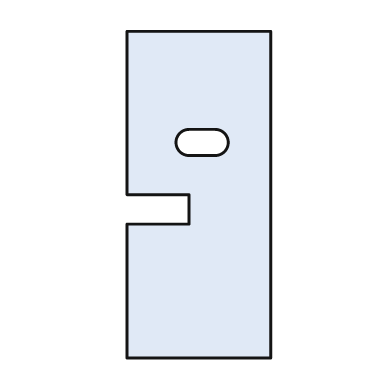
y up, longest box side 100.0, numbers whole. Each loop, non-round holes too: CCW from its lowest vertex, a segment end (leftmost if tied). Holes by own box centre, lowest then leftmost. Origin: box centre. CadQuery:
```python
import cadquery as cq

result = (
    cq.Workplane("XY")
    .moveTo(-22.0, -50.0)
    .lineTo(22.0, -50.0)
    .lineTo(22.0, 50.0)
    .lineTo(-22.0, 50.0)
    .lineTo(-22.0, 0.0)
    .lineTo(-3.0, 0.0)
    .lineTo(-3.0, -9.0)
    .lineTo(-22.0, -9.0)
    .close()
    .moveTo(-3.0, 12.0)
    .lineTo(5.0, 12.0)
    .threePointArc((9.0, 16.0), (5.0, 20.0))
    .lineTo(-3.0, 20.0)
    .threePointArc((-7.0, 16.0), (-3.0, 12.0))
    .close()
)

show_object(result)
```